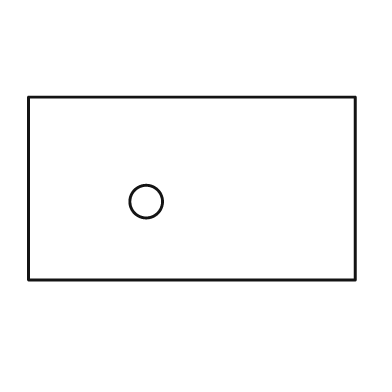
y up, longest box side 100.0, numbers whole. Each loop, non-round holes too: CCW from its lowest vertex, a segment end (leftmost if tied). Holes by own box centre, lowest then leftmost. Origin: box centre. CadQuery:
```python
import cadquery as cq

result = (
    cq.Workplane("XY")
    .moveTo(-50.0, -28.0)
    .lineTo(50.0, -28.0)
    .lineTo(50.0, 28.0)
    .lineTo(-50.0, 28.0)
    .close()
    .moveTo(-14.0, -4.0)
    .circle(5.0)
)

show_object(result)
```